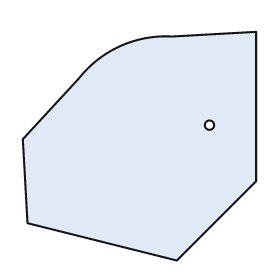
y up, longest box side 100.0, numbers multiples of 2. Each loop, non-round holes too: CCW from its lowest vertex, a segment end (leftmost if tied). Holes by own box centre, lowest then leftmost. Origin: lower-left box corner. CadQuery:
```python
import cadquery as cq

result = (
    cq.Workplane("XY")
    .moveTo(66.0, 0.0)
    .lineTo(100.0, 34.0)
    .lineTo(100.0, 98.0)
    .lineTo(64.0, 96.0)
    .threePointArc((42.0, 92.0), (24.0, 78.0))
    .lineTo(0.0, 52.0)
    .lineTo(2.0, 16.0)
    .close()
    .moveTo(80.0, 58.0)
    .circle(2.0)
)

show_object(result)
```